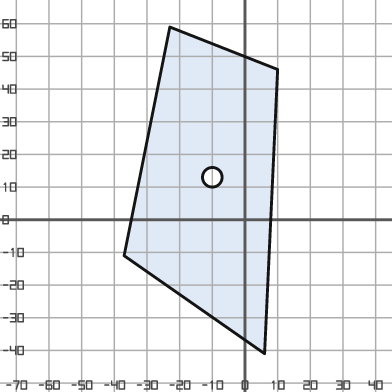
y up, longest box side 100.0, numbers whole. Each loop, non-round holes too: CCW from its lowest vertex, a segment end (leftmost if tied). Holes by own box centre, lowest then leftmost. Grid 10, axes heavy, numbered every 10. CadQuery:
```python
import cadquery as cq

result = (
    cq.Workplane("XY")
    .moveTo(6.0, -41.0)
    .lineTo(10.0, 46.0)
    .lineTo(-23.0, 59.0)
    .lineTo(-37.0, -11.0)
    .close()
    .moveTo(-10.0, 13.0)
    .circle(3.0)
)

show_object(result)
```